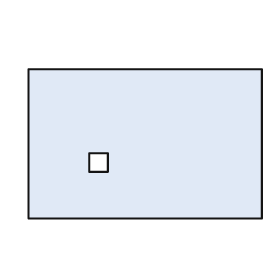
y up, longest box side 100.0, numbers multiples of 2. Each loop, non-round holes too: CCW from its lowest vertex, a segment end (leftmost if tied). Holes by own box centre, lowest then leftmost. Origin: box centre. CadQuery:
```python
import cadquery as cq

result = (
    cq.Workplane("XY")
    .moveTo(-50.0, -32.0)
    .lineTo(50.0, -32.0)
    .lineTo(50.0, 32.0)
    .lineTo(-50.0, 32.0)
    .close()
    .moveTo(-24.0, -12.0)
    .lineTo(-16.0, -12.0)
    .lineTo(-16.0, -4.0)
    .lineTo(-24.0, -4.0)
    .close()
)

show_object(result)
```